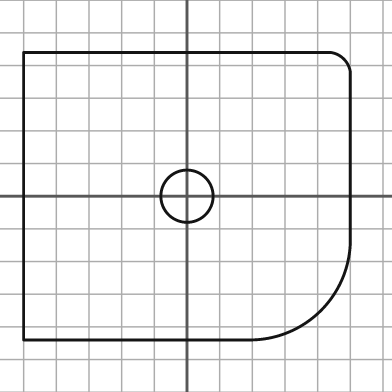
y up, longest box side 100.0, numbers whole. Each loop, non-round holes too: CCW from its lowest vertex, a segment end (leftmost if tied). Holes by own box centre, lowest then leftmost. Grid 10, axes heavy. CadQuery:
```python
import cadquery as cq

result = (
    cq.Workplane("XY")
    .moveTo(-50.0, -44.0)
    .lineTo(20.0, -44.0)
    .threePointArc((41.0, -35.0), (50.0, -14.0))
    .lineTo(50.0, 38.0)
    .threePointArc((48.0, 42.0), (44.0, 44.0))
    .lineTo(-50.0, 44.0)
    .close()
    .moveTo(0.0, 0.0)
    .circle(8.0)
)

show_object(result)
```